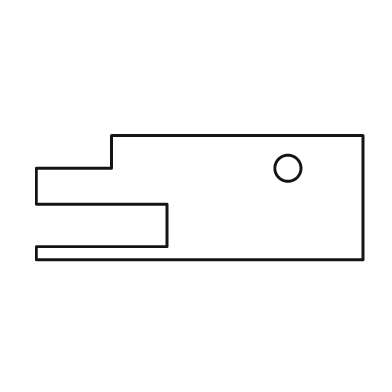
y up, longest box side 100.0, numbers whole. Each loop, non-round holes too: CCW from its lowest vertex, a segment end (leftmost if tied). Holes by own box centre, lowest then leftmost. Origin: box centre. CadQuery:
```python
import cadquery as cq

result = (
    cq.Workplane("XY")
    .moveTo(-50.0, -19.0)
    .lineTo(50.0, -19.0)
    .lineTo(50.0, 19.0)
    .lineTo(-27.0, 19.0)
    .lineTo(-27.0, 9.0)
    .lineTo(-50.0, 9.0)
    .lineTo(-50.0, -2.0)
    .lineTo(-10.0, -2.0)
    .lineTo(-10.0, -15.0)
    .lineTo(-50.0, -15.0)
    .close()
    .moveTo(27.0, 9.0)
    .circle(4.0)
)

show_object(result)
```